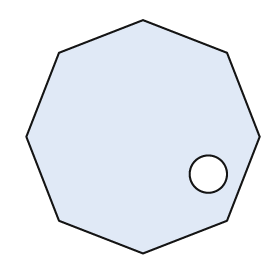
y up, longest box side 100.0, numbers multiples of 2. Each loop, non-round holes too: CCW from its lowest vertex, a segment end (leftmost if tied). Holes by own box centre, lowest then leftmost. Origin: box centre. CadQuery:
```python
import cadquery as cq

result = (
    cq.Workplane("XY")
    .moveTo(0.0, -50.0)
    .lineTo(36.0, -36.0)
    .lineTo(50.0, 0.0)
    .lineTo(36.0, 36.0)
    .lineTo(0.0, 50.0)
    .lineTo(-36.0, 36.0)
    .lineTo(-50.0, 0.0)
    .lineTo(-36.0, -36.0)
    .close()
    .moveTo(28.0, -16.0)
    .circle(8.0)
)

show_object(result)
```